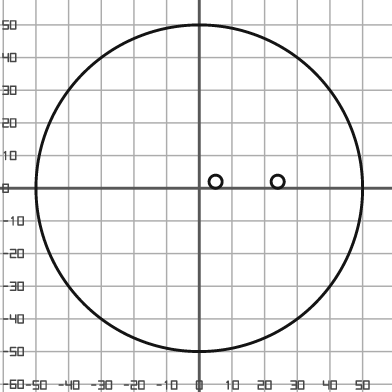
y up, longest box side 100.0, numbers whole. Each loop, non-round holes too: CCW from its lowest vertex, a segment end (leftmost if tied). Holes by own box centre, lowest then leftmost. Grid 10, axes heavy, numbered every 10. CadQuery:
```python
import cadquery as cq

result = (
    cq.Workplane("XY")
    .moveTo(0.0, 0.0)
    .circle(50.0)
    .moveTo(5.0, 2.0)
    .circle(2.0)
    .moveTo(24.0, 2.0)
    .circle(2.0)
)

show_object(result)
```